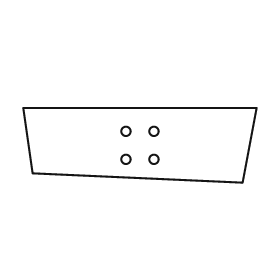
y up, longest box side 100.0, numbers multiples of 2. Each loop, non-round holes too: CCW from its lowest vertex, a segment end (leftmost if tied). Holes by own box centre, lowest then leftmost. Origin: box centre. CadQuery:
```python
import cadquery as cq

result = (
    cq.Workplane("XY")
    .moveTo(44.0, -16.0)
    .lineTo(50.0, 16.0)
    .lineTo(-50.0, 16.0)
    .lineTo(-46.0, -12.0)
    .close()
    .moveTo(-6.0, -6.0)
    .circle(2.0)
    .moveTo(6.0, -6.0)
    .circle(2.0)
    .moveTo(-6.0, 6.0)
    .circle(2.0)
    .moveTo(6.0, 6.0)
    .circle(2.0)
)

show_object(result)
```